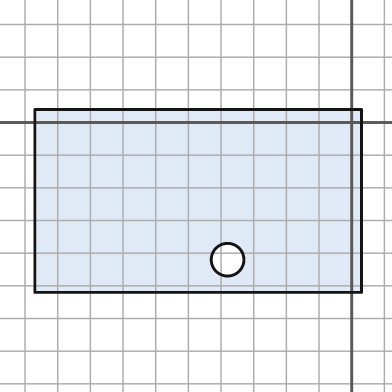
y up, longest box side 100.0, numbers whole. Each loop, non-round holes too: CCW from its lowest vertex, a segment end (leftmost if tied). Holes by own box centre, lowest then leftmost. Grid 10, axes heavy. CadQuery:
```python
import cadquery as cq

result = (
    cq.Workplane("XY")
    .moveTo(-97.0, -52.0)
    .lineTo(3.0, -52.0)
    .lineTo(3.0, 4.0)
    .lineTo(-97.0, 4.0)
    .close()
    .moveTo(-38.0, -42.0)
    .circle(5.0)
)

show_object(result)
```